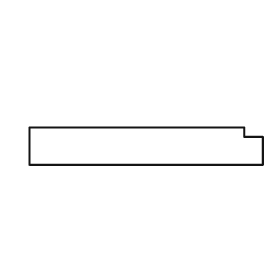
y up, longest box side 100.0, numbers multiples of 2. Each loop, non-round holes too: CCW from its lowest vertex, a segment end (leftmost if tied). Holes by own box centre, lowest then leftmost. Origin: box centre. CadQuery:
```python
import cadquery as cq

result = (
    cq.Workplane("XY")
    .moveTo(-50.0, -8.0)
    .lineTo(50.0, -8.0)
    .lineTo(50.0, 4.0)
    .lineTo(42.0, 4.0)
    .lineTo(42.0, 8.0)
    .lineTo(-50.0, 8.0)
    .close()
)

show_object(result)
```